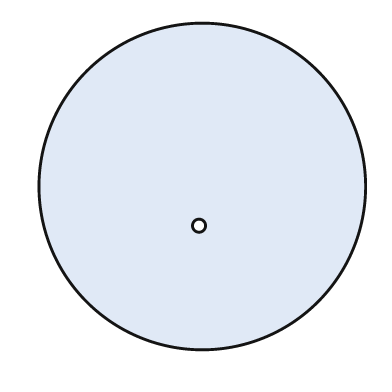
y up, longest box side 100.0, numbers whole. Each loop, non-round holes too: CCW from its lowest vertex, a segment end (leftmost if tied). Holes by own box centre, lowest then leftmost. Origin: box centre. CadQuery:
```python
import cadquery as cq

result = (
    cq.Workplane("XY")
    .moveTo(0.0, 0.0)
    .circle(50.0)
    .moveTo(-1.0, -12.0)
    .circle(2.0)
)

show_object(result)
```